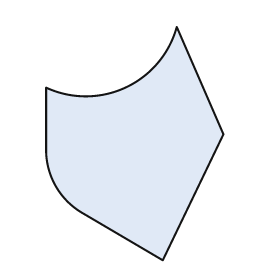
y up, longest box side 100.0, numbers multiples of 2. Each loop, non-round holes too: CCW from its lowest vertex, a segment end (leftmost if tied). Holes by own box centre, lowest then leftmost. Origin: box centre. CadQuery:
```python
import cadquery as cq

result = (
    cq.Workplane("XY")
    .moveTo(12.0, -50.0)
    .lineTo(38.0, 4.0)
    .lineTo(18.0, 50.0)
    .threePointArc((-4.0, 24.0), (-38.0, 24.0))
    .lineTo(-38.0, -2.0)
    .threePointArc((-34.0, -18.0), (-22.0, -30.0))
    .close()
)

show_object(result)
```